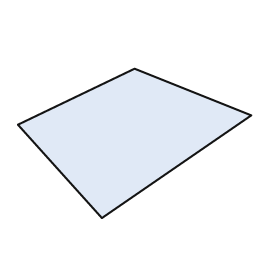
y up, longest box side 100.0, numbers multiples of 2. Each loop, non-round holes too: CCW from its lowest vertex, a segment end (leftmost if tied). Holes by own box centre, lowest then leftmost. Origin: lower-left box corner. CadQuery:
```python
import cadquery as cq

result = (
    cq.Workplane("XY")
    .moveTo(36.0, 0.0)
    .lineTo(100.0, 44.0)
    .lineTo(50.0, 64.0)
    .lineTo(0.0, 40.0)
    .close()
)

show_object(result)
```